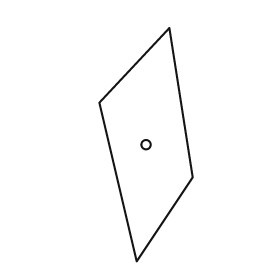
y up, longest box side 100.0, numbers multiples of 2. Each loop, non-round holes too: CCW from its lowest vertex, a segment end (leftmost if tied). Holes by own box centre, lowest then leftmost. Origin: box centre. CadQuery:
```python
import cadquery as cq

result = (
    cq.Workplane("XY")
    .moveTo(-4.0, -50.0)
    .lineTo(20.0, -14.0)
    .lineTo(10.0, 50.0)
    .lineTo(-20.0, 18.0)
    .close()
    .moveTo(0.0, 0.0)
    .circle(2.0)
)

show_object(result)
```